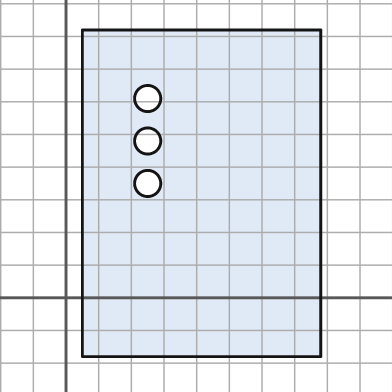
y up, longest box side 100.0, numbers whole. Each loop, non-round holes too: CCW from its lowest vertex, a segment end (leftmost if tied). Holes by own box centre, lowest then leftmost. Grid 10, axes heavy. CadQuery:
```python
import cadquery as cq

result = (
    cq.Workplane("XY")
    .moveTo(5.0, -18.0)
    .lineTo(78.0, -18.0)
    .lineTo(78.0, 82.0)
    .lineTo(5.0, 82.0)
    .close()
    .moveTo(25.0, 35.0)
    .circle(4.0)
    .moveTo(25.0, 48.0)
    .circle(4.0)
    .moveTo(25.0, 61.0)
    .circle(4.0)
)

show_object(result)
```